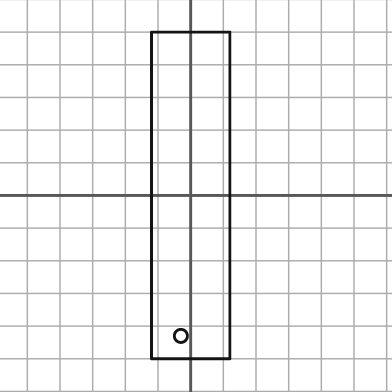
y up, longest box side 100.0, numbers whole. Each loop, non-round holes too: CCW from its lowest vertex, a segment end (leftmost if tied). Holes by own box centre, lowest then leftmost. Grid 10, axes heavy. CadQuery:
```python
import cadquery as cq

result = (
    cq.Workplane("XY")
    .moveTo(-12.0, -50.0)
    .lineTo(12.0, -50.0)
    .lineTo(12.0, 50.0)
    .lineTo(-12.0, 50.0)
    .close()
    .moveTo(-3.0, -43.0)
    .circle(2.0)
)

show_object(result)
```